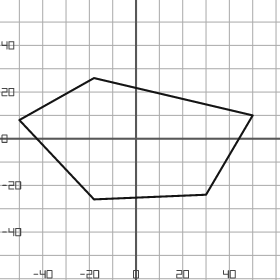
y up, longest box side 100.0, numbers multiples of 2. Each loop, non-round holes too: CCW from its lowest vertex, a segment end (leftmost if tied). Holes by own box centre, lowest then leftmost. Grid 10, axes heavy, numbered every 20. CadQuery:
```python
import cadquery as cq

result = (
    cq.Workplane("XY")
    .moveTo(-18.0, -26.0)
    .lineTo(30.0, -24.0)
    .lineTo(50.0, 10.0)
    .lineTo(-18.0, 26.0)
    .lineTo(-50.0, 8.0)
    .close()
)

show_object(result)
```